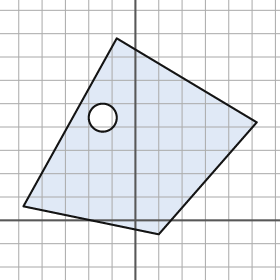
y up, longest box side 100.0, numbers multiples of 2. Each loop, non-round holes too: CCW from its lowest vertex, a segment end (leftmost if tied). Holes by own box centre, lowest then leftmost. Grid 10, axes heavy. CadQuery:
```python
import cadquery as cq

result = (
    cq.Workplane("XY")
    .moveTo(10.0, -6.0)
    .lineTo(52.0, 42.0)
    .lineTo(-8.0, 78.0)
    .lineTo(-48.0, 6.0)
    .close()
    .moveTo(-14.0, 44.0)
    .circle(6.0)
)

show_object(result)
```